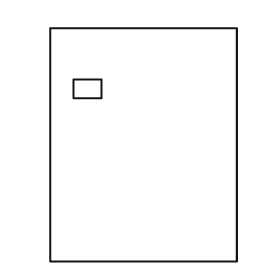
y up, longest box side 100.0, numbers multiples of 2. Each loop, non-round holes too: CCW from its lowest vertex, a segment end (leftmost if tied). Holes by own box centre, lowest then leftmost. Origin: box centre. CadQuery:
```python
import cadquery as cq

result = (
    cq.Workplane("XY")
    .moveTo(-40.0, -50.0)
    .lineTo(40.0, -50.0)
    .lineTo(40.0, 50.0)
    .lineTo(-40.0, 50.0)
    .close()
    .moveTo(-30.0, 20.0)
    .lineTo(-18.0, 20.0)
    .lineTo(-18.0, 28.0)
    .lineTo(-30.0, 28.0)
    .close()
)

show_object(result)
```